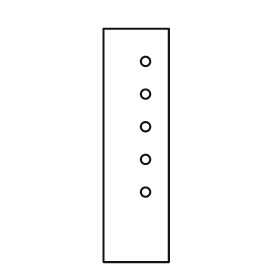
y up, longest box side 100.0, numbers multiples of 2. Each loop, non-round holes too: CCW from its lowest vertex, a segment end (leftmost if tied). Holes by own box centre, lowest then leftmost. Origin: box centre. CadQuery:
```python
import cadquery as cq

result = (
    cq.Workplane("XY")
    .moveTo(-14.0, -50.0)
    .lineTo(14.0, -50.0)
    .lineTo(14.0, 50.0)
    .lineTo(-14.0, 50.0)
    .close()
    .moveTo(4.0, -20.0)
    .circle(2.0)
    .moveTo(4.0, -6.0)
    .circle(2.0)
    .moveTo(4.0, 8.0)
    .circle(2.0)
    .moveTo(4.0, 22.0)
    .circle(2.0)
    .moveTo(4.0, 36.0)
    .circle(2.0)
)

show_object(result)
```